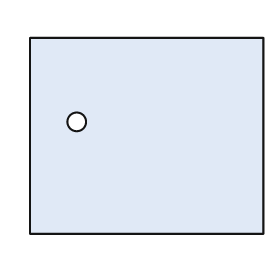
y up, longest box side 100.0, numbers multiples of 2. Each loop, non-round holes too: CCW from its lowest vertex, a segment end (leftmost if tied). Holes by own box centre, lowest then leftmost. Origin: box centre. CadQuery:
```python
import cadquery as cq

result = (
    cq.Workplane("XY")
    .moveTo(-50.0, -42.0)
    .lineTo(50.0, -42.0)
    .lineTo(50.0, 42.0)
    .lineTo(-50.0, 42.0)
    .close()
    .moveTo(-30.0, 6.0)
    .circle(4.0)
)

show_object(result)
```